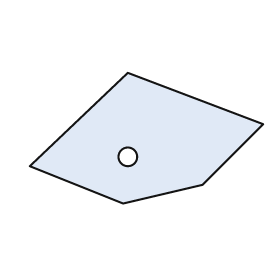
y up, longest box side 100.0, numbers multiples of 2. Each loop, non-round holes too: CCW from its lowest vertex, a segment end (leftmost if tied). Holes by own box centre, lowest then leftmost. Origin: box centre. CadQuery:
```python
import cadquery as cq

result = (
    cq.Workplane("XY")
    .moveTo(-10.0, -28.0)
    .lineTo(24.0, -20.0)
    .lineTo(50.0, 6.0)
    .lineTo(-8.0, 28.0)
    .lineTo(-50.0, -12.0)
    .close()
    .moveTo(-8.0, -8.0)
    .circle(4.0)
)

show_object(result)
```